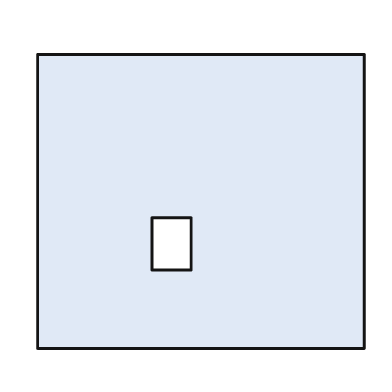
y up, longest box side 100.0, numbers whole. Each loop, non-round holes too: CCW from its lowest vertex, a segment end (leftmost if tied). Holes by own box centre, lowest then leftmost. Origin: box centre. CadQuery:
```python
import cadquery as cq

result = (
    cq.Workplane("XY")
    .moveTo(-50.0, -45.0)
    .lineTo(50.0, -45.0)
    .lineTo(50.0, 45.0)
    .lineTo(-50.0, 45.0)
    .close()
    .moveTo(-15.0, -21.0)
    .lineTo(-3.0, -21.0)
    .lineTo(-3.0, -5.0)
    .lineTo(-15.0, -5.0)
    .close()
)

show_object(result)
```